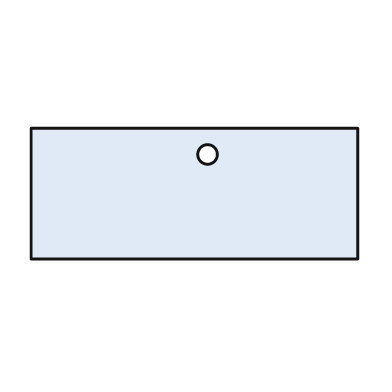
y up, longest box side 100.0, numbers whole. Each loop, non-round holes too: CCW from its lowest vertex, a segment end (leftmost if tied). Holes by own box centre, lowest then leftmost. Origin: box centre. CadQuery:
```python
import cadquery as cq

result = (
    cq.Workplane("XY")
    .moveTo(-50.0, -20.0)
    .lineTo(50.0, -20.0)
    .lineTo(50.0, 20.0)
    .lineTo(-50.0, 20.0)
    .close()
    .moveTo(4.0, 12.0)
    .circle(3.0)
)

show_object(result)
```